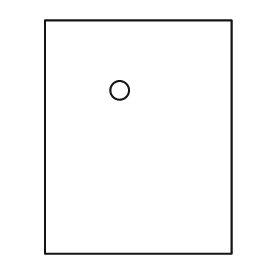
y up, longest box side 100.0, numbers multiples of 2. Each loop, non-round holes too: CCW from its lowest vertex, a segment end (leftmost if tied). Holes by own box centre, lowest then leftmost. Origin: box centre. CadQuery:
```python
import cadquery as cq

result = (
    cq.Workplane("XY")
    .moveTo(-40.0, -50.0)
    .lineTo(40.0, -50.0)
    .lineTo(40.0, 50.0)
    .lineTo(-40.0, 50.0)
    .close()
    .moveTo(-8.0, 20.0)
    .circle(4.0)
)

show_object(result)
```